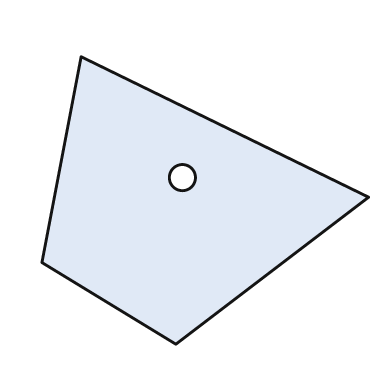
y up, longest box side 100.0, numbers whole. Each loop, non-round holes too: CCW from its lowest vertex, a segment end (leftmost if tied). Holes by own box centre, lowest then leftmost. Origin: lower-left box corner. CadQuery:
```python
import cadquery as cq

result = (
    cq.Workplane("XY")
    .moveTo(41.0, 0.0)
    .lineTo(100.0, 45.0)
    .lineTo(12.0, 88.0)
    .lineTo(0.0, 25.0)
    .close()
    .moveTo(43.0, 51.0)
    .circle(4.0)
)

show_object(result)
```